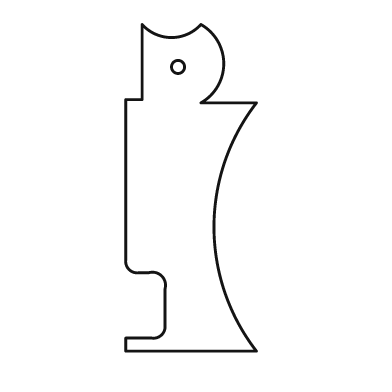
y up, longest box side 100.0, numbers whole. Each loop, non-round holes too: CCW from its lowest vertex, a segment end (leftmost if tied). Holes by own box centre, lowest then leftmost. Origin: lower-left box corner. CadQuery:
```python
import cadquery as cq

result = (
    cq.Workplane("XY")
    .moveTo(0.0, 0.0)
    .lineTo(40.0, 0.0)
    .threePointArc((27.0, 38.0), (40.0, 76.0))
    .lineTo(23.0, 76.0)
    .threePointArc((30.0, 88.0), (23.0, 100.0))
    .threePointArc((14.0, 96.0), (5.0, 100.0))
    .lineTo(5.0, 77.0)
    .lineTo(0.0, 77.0)
    .lineTo(0.0, 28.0)
    .threePointArc((1.0, 25.0), (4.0, 24.0))
    .lineTo(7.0, 24.0)
    .threePointArc((11.0, 23.0), (12.0, 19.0))
    .lineTo(12.0, 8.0)
    .threePointArc((11.0, 5.0), (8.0, 4.0))
    .lineTo(0.0, 4.0)
    .close()
    .moveTo(16.0, 87.0)
    .circle(2.0)
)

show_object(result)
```